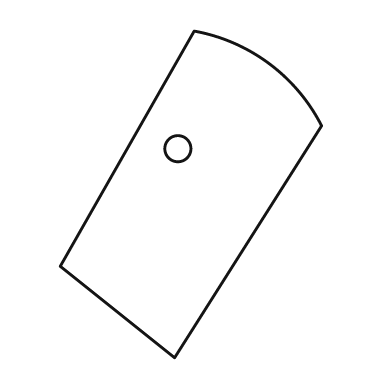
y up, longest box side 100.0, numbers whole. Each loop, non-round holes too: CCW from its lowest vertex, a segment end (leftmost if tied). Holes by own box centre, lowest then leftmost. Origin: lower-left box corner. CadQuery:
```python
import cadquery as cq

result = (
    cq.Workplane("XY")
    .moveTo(35.0, 0.0)
    .lineTo(80.0, 71.0)
    .threePointArc((64.0, 90.0), (41.0, 100.0))
    .lineTo(0.0, 28.0)
    .close()
    .moveTo(36.0, 64.0)
    .circle(4.0)
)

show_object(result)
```